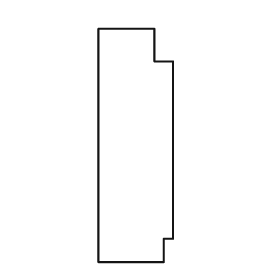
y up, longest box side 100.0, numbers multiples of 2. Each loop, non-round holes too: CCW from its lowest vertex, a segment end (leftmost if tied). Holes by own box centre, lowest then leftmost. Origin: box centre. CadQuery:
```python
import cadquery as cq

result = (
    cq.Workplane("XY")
    .moveTo(-16.0, -50.0)
    .lineTo(12.0, -50.0)
    .lineTo(12.0, -40.0)
    .lineTo(16.0, -40.0)
    .lineTo(16.0, 36.0)
    .lineTo(8.0, 36.0)
    .lineTo(8.0, 50.0)
    .lineTo(-16.0, 50.0)
    .close()
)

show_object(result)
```